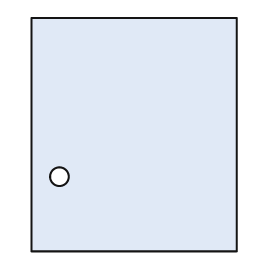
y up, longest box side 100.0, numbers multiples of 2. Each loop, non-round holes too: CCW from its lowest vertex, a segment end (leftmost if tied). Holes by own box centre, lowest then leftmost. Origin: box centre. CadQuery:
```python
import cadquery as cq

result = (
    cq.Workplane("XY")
    .moveTo(-44.0, -50.0)
    .lineTo(44.0, -50.0)
    .lineTo(44.0, 50.0)
    .lineTo(-44.0, 50.0)
    .close()
    .moveTo(-32.0, -18.0)
    .circle(4.0)
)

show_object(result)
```